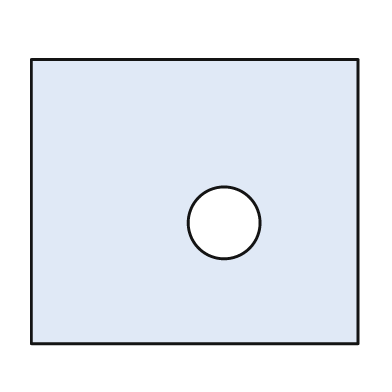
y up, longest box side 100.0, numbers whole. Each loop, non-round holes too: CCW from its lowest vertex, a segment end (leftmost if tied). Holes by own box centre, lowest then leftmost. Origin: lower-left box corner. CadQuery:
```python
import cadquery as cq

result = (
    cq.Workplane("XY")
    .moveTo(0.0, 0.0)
    .lineTo(100.0, 0.0)
    .lineTo(100.0, 87.0)
    .lineTo(0.0, 87.0)
    .close()
    .moveTo(59.0, 37.0)
    .circle(11.0)
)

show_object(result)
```